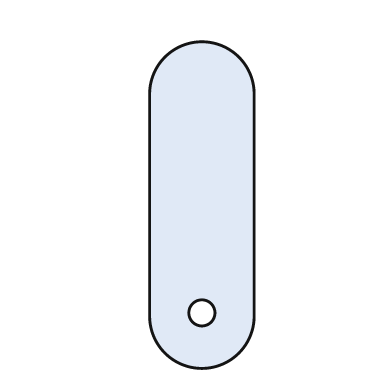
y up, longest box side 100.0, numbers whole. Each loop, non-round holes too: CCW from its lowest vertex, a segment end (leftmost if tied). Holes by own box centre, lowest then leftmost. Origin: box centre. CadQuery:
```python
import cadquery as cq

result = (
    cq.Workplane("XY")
    .moveTo(-16.0, -34.0)
    .threePointArc((0.0, -50.0), (16.0, -34.0))
    .lineTo(16.0, 34.0)
    .threePointArc((0.0, 50.0), (-16.0, 34.0))
    .close()
    .moveTo(0.0, -33.0)
    .circle(4.0)
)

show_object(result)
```